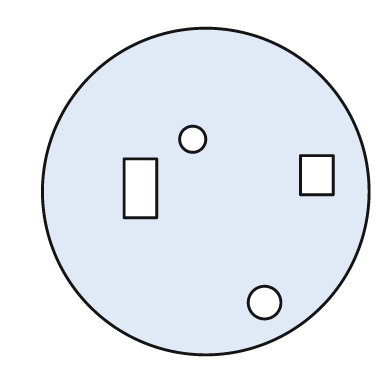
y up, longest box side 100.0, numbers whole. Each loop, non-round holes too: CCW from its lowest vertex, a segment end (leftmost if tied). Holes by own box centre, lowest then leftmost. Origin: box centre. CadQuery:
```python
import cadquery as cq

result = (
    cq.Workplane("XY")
    .moveTo(0.0, 0.0)
    .circle(50.0)
    .moveTo(18.0, -34.0)
    .circle(5.0)
    .moveTo(-25.0, -8.0)
    .lineTo(-15.0, -8.0)
    .lineTo(-15.0, 10.0)
    .lineTo(-25.0, 10.0)
    .close()
    .moveTo(29.0, -1.0)
    .lineTo(39.0, -1.0)
    .lineTo(39.0, 11.0)
    .lineTo(29.0, 11.0)
    .close()
    .moveTo(-4.0, 16.0)
    .circle(4.0)
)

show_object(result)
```